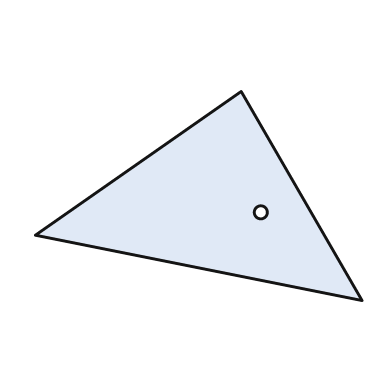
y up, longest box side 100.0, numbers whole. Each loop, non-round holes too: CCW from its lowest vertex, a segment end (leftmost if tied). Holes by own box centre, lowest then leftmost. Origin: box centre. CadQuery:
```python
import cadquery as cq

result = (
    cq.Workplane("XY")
    .moveTo(50.0, -32.0)
    .lineTo(13.0, 32.0)
    .lineTo(-50.0, -12.0)
    .close()
    .moveTo(19.0, -5.0)
    .circle(2.0)
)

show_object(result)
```